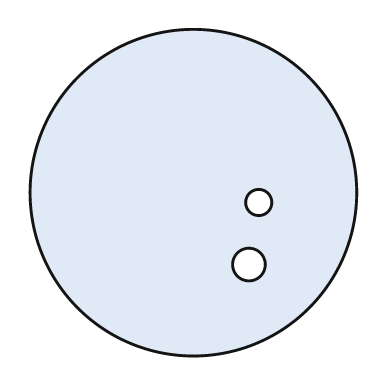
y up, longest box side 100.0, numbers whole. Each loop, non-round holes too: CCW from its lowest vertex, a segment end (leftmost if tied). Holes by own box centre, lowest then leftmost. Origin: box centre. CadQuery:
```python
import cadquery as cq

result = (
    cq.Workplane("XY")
    .moveTo(0.0, 0.0)
    .circle(50.0)
    .moveTo(17.0, -22.0)
    .circle(5.0)
    .moveTo(20.0, -3.0)
    .circle(4.0)
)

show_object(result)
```